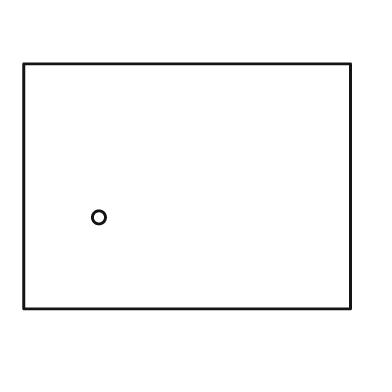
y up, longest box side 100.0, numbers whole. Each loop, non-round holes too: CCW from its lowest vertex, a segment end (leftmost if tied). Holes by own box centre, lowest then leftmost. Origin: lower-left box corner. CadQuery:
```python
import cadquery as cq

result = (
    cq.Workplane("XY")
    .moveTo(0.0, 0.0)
    .lineTo(100.0, 0.0)
    .lineTo(100.0, 75.0)
    .lineTo(0.0, 75.0)
    .close()
    .moveTo(23.0, 28.0)
    .circle(2.0)
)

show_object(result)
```